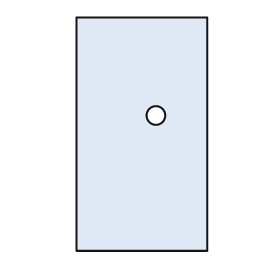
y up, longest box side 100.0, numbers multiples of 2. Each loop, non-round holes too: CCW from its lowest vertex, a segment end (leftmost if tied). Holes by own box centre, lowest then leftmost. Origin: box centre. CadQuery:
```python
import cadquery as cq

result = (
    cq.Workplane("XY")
    .moveTo(-28.0, -50.0)
    .lineTo(28.0, -50.0)
    .lineTo(28.0, 50.0)
    .lineTo(-28.0, 50.0)
    .close()
    .moveTo(6.0, 8.0)
    .circle(4.0)
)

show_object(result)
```